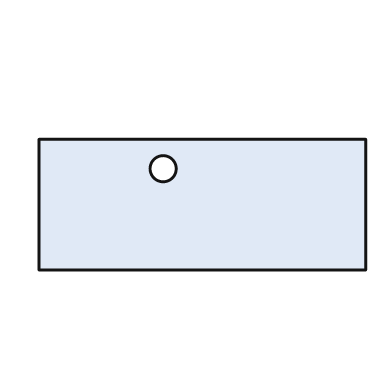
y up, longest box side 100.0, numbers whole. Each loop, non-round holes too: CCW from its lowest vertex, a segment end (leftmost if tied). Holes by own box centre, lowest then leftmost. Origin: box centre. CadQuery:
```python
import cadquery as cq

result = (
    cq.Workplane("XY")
    .moveTo(-50.0, -20.0)
    .lineTo(50.0, -20.0)
    .lineTo(50.0, 20.0)
    .lineTo(-50.0, 20.0)
    .close()
    .moveTo(-12.0, 11.0)
    .circle(4.0)
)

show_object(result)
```